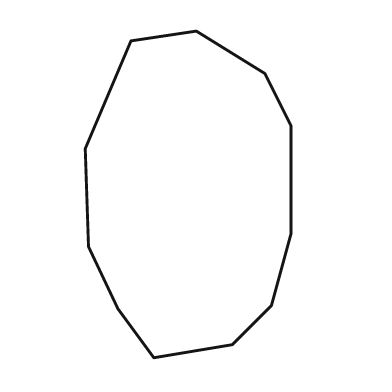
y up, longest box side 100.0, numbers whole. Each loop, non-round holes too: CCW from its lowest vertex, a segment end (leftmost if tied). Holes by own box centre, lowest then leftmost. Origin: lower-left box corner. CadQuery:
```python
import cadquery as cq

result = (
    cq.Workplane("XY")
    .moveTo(21.0, 0.0)
    .lineTo(45.0, 4.0)
    .lineTo(57.0, 16.0)
    .lineTo(63.0, 38.0)
    .lineTo(63.0, 71.0)
    .lineTo(55.0, 87.0)
    .lineTo(34.0, 100.0)
    .lineTo(14.0, 97.0)
    .lineTo(0.0, 64.0)
    .lineTo(1.0, 34.0)
    .lineTo(10.0, 15.0)
    .close()
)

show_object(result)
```